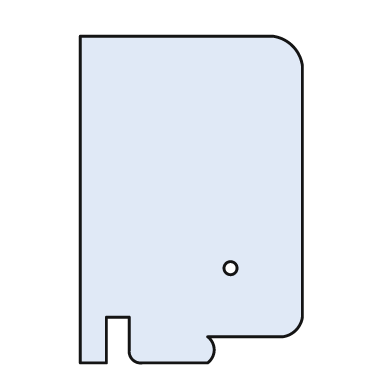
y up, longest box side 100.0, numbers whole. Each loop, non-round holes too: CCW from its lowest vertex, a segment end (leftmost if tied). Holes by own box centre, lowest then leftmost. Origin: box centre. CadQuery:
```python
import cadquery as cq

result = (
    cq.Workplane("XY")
    .moveTo(-34.0, -50.0)
    .lineTo(-26.0, -50.0)
    .lineTo(-26.0, -36.0)
    .lineTo(-19.0, -36.0)
    .lineTo(-19.0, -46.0)
    .threePointArc((-18.0, -49.0), (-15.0, -50.0))
    .lineTo(5.0, -50.0)
    .threePointArc((7.0, -46.0), (5.0, -42.0))
    .lineTo(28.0, -42.0)
    .threePointArc((32.0, -40.0), (34.0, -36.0))
    .lineTo(34.0, 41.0)
    .threePointArc((31.0, 47.0), (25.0, 50.0))
    .lineTo(-34.0, 50.0)
    .close()
    .moveTo(12.0, -21.0)
    .circle(2.0)
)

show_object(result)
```